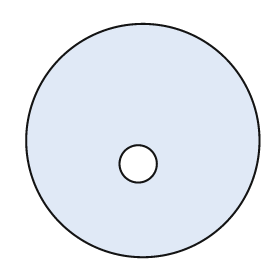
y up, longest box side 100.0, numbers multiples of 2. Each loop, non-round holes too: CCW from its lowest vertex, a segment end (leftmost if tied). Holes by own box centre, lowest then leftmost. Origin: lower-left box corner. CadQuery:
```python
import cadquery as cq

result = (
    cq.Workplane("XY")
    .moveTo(50.0, 50.0)
    .circle(50.0)
    .moveTo(48.0, 40.0)
    .circle(8.0)
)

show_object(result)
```